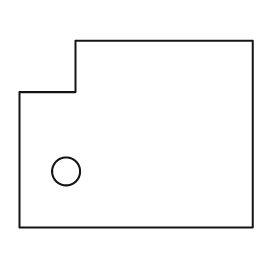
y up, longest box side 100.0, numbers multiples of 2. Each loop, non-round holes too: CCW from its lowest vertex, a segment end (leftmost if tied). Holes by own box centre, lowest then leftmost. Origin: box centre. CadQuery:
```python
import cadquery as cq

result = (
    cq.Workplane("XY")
    .moveTo(-50.0, -40.0)
    .lineTo(50.0, -40.0)
    .lineTo(50.0, 40.0)
    .lineTo(-26.0, 40.0)
    .lineTo(-26.0, 18.0)
    .lineTo(-50.0, 18.0)
    .close()
    .moveTo(-30.0, -16.0)
    .circle(6.0)
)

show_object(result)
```